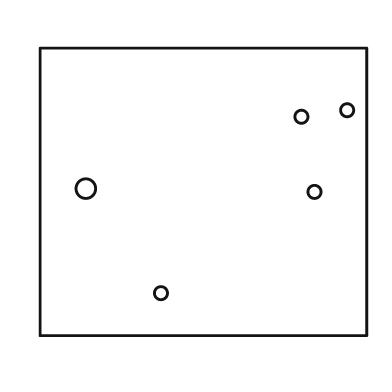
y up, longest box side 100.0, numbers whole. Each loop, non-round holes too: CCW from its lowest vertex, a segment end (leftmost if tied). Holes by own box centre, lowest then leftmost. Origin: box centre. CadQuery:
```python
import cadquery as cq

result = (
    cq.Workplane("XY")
    .moveTo(-50.0, -44.0)
    .lineTo(50.0, -44.0)
    .lineTo(50.0, 44.0)
    .lineTo(-50.0, 44.0)
    .close()
    .moveTo(-13.0, -31.0)
    .circle(2.0)
    .moveTo(34.0, 0.0)
    .circle(2.0)
    .moveTo(-36.0, 1.0)
    .circle(3.0)
    .moveTo(30.0, 23.0)
    .circle(2.0)
    .moveTo(44.0, 25.0)
    .circle(2.0)
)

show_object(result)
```